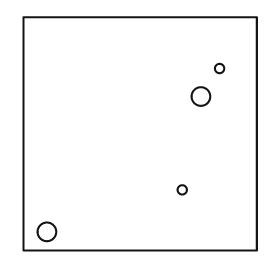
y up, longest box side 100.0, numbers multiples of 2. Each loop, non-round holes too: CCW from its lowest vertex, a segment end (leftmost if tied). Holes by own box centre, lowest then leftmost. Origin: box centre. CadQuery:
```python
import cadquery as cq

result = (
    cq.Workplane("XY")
    .moveTo(-50.0, -50.0)
    .lineTo(50.0, -50.0)
    .lineTo(50.0, 50.0)
    .lineTo(-50.0, 50.0)
    .close()
    .moveTo(-40.0, -42.0)
    .circle(4.0)
    .moveTo(18.0, -24.0)
    .circle(2.0)
    .moveTo(26.0, 16.0)
    .circle(4.0)
    .moveTo(34.0, 28.0)
    .circle(2.0)
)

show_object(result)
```